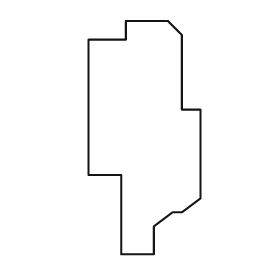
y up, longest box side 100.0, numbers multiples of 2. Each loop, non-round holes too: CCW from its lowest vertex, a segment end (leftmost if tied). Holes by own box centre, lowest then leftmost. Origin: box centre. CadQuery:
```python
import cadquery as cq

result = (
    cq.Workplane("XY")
    .moveTo(-10.0, -50.0)
    .lineTo(4.0, -50.0)
    .lineTo(4.0, -38.0)
    .lineTo(12.0, -32.0)
    .lineTo(16.0, -32.0)
    .lineTo(24.0, -26.0)
    .lineTo(24.0, 12.0)
    .lineTo(16.0, 12.0)
    .lineTo(16.0, 44.0)
    .lineTo(10.0, 50.0)
    .lineTo(-8.0, 50.0)
    .lineTo(-8.0, 42.0)
    .lineTo(-24.0, 42.0)
    .lineTo(-24.0, -16.0)
    .lineTo(-10.0, -16.0)
    .close()
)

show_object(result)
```